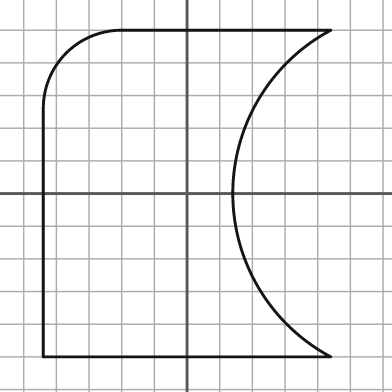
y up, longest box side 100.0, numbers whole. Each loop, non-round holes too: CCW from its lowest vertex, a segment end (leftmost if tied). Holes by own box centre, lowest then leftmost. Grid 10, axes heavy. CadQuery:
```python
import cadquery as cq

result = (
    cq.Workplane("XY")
    .moveTo(-44.0, -50.0)
    .lineTo(44.0, -50.0)
    .threePointArc((14.0, 0.0), (44.0, 50.0))
    .lineTo(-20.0, 50.0)
    .threePointArc((-37.0, 43.0), (-44.0, 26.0))
    .close()
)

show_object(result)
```